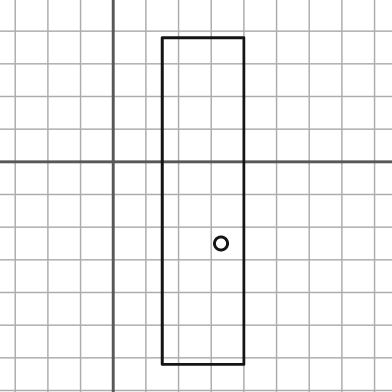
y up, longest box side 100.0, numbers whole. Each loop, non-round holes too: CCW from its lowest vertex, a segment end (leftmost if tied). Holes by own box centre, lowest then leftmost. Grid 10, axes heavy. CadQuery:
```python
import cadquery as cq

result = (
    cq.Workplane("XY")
    .moveTo(15.0, -62.0)
    .lineTo(40.0, -62.0)
    .lineTo(40.0, 38.0)
    .lineTo(15.0, 38.0)
    .close()
    .moveTo(33.0, -25.0)
    .circle(2.0)
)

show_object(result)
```